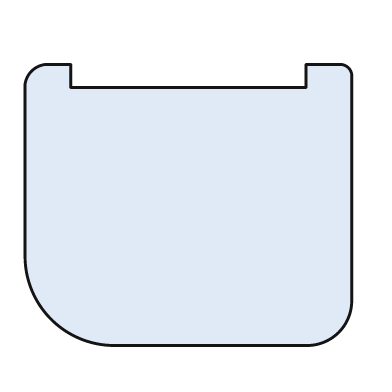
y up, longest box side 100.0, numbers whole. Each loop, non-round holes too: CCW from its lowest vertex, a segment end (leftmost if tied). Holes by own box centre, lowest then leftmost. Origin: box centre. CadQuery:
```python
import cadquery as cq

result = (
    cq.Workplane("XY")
    .moveTo(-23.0, -43.0)
    .lineTo(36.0, -43.0)
    .threePointArc((46.0, -39.0), (50.0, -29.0))
    .lineTo(50.0, 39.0)
    .threePointArc((49.0, 42.0), (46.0, 43.0))
    .lineTo(36.0, 43.0)
    .lineTo(36.0, 36.0)
    .lineTo(-36.0, 36.0)
    .lineTo(-36.0, 43.0)
    .lineTo(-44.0, 43.0)
    .threePointArc((-48.0, 41.0), (-50.0, 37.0))
    .lineTo(-50.0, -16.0)
    .threePointArc((-42.0, -35.0), (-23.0, -43.0))
    .close()
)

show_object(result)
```